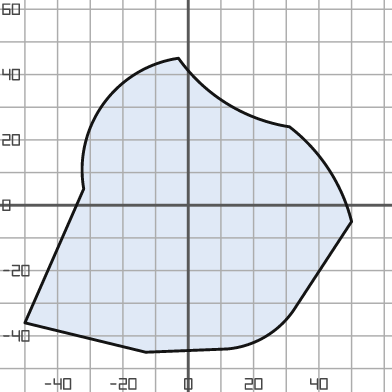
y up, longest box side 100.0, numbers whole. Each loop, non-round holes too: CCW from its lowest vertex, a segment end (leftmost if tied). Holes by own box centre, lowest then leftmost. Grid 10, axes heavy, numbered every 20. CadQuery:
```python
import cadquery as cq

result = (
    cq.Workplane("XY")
    .moveTo(-13.0, -45.0)
    .lineTo(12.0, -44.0)
    .threePointArc((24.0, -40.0), (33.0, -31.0))
    .lineTo(50.0, -5.0)
    .threePointArc((43.0, 11.0), (31.0, 24.0))
    .threePointArc((12.0, 31.0), (-3.0, 45.0))
    .threePointArc((-26.0, 31.0), (-32.0, 5.0))
    .lineTo(-50.0, -36.0)
    .close()
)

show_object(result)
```